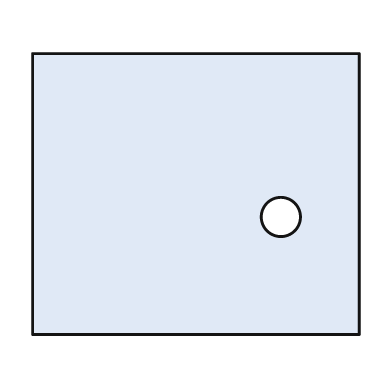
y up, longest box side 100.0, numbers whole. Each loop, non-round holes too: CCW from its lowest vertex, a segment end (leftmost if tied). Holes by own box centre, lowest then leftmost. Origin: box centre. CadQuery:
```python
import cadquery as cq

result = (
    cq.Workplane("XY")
    .moveTo(-50.0, -43.0)
    .lineTo(50.0, -43.0)
    .lineTo(50.0, 43.0)
    .lineTo(-50.0, 43.0)
    .close()
    .moveTo(26.0, -7.0)
    .circle(6.0)
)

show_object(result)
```